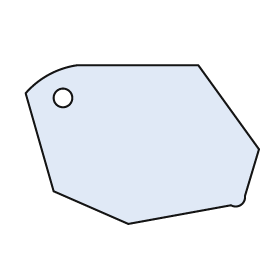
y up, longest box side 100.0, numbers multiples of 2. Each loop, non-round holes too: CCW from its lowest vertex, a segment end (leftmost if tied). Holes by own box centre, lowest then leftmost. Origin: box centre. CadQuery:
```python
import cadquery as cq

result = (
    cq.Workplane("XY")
    .moveTo(-6.0, -34.0)
    .lineTo(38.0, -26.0)
    .threePointArc((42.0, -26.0), (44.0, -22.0))
    .lineTo(50.0, -2.0)
    .lineTo(24.0, 34.0)
    .lineTo(-28.0, 34.0)
    .threePointArc((-40.0, 30.0), (-50.0, 22.0))
    .lineTo(-38.0, -20.0)
    .close()
    .moveTo(-34.0, 20.0)
    .circle(4.0)
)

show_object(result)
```